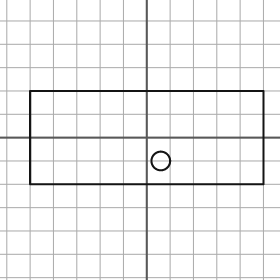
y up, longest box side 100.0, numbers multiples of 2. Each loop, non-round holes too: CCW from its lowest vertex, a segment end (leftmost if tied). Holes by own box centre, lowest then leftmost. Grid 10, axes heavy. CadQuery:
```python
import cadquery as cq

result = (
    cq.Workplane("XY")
    .moveTo(-50.0, -20.0)
    .lineTo(50.0, -20.0)
    .lineTo(50.0, 20.0)
    .lineTo(-50.0, 20.0)
    .close()
    .moveTo(6.0, -10.0)
    .circle(4.0)
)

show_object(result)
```